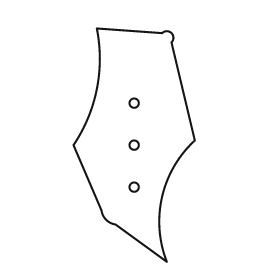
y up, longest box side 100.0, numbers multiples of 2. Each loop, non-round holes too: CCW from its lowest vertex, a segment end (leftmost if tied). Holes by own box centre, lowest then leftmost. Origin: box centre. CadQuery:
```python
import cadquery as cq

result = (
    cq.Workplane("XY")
    .moveTo(14.0, -50.0)
    .threePointArc((12.0, -22.0), (26.0, 2.0))
    .lineTo(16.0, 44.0)
    .threePointArc((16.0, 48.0), (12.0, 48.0))
    .lineTo(-16.0, 50.0)
    .threePointArc((-16.0, 24.0), (-26.0, 0.0))
    .lineTo(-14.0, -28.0)
    .threePointArc((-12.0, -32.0), (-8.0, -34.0))
    .close()
    .moveTo(0.0, -18.0)
    .circle(2.0)
    .moveTo(0.0, 0.0)
    .circle(2.0)
    .moveTo(0.0, 18.0)
    .circle(2.0)
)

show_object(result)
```